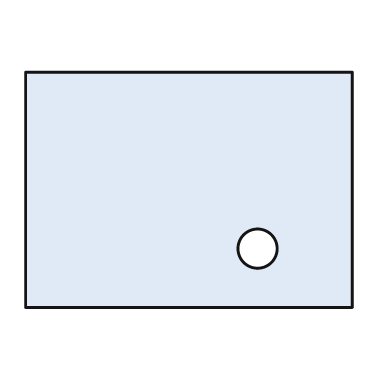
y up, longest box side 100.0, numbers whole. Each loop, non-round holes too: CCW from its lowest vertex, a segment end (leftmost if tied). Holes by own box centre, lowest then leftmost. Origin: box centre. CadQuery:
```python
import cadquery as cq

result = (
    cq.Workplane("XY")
    .moveTo(-50.0, -36.0)
    .lineTo(50.0, -36.0)
    .lineTo(50.0, 36.0)
    .lineTo(-50.0, 36.0)
    .close()
    .moveTo(21.0, -18.0)
    .circle(6.0)
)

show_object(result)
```